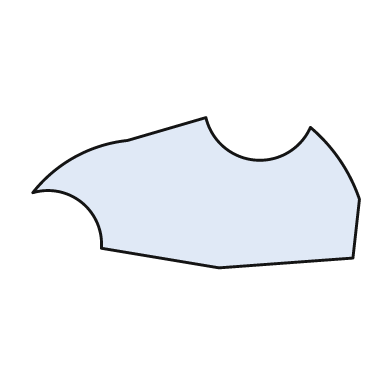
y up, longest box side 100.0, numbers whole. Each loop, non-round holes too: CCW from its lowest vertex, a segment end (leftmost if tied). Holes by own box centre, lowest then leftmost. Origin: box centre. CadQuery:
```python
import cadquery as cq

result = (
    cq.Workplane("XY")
    .moveTo(7.0, -23.0)
    .lineTo(48.0, -20.0)
    .lineTo(50.0, -2.0)
    .threePointArc((44.0, 10.0), (35.0, 20.0))
    .threePointArc((18.0, 10.0), (3.0, 23.0))
    .lineTo(-21.0, 16.0)
    .threePointArc((-37.0, 11.0), (-50.0, 0.0))
    .threePointArc((-35.0, -3.0), (-29.0, -17.0))
    .close()
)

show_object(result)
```